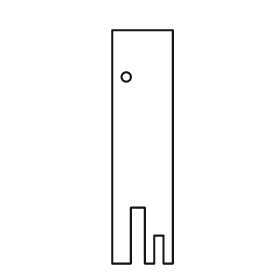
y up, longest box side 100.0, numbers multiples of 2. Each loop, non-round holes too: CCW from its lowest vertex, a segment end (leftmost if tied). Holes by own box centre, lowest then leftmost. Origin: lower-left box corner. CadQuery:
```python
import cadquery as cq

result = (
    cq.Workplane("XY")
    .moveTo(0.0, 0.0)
    .lineTo(8.0, 0.0)
    .lineTo(8.0, 24.0)
    .lineTo(14.0, 24.0)
    .lineTo(14.0, 0.0)
    .lineTo(18.0, 0.0)
    .lineTo(18.0, 12.0)
    .lineTo(22.0, 12.0)
    .lineTo(22.0, 0.0)
    .lineTo(26.0, 0.0)
    .lineTo(26.0, 100.0)
    .lineTo(0.0, 100.0)
    .close()
    .moveTo(6.0, 80.0)
    .circle(2.0)
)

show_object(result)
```